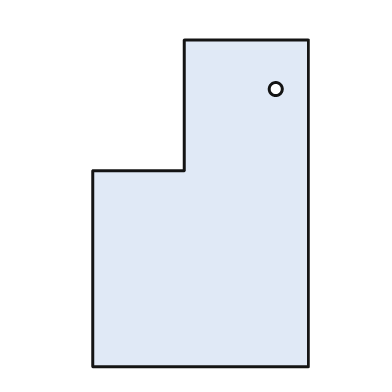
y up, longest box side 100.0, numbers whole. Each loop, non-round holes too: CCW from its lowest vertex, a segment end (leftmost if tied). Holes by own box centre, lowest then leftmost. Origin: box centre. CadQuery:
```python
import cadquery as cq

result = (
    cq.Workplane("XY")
    .moveTo(-33.0, -50.0)
    .lineTo(33.0, -50.0)
    .lineTo(33.0, 50.0)
    .lineTo(-5.0, 50.0)
    .lineTo(-5.0, 10.0)
    .lineTo(-33.0, 10.0)
    .close()
    .moveTo(23.0, 35.0)
    .circle(2.0)
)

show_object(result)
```